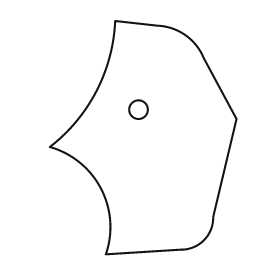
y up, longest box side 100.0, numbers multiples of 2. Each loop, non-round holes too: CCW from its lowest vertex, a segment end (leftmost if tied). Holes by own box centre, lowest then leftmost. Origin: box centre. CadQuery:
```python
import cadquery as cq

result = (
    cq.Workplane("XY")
    .moveTo(-16.0, -50.0)
    .lineTo(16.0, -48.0)
    .threePointArc((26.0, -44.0), (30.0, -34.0))
    .lineTo(40.0, 8.0)
    .lineTo(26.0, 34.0)
    .threePointArc((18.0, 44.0), (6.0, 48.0))
    .lineTo(-12.0, 50.0)
    .threePointArc((-20.0, 20.0), (-40.0, -4.0))
    .threePointArc((-18.0, -22.0), (-16.0, -50.0))
    .close()
    .moveTo(-2.0, 12.0)
    .circle(4.0)
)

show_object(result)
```